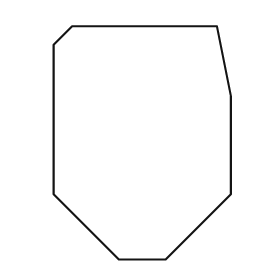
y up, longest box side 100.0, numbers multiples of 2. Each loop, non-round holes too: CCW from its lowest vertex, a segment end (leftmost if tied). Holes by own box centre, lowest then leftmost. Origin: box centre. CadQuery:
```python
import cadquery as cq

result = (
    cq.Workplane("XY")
    .moveTo(-10.0, -50.0)
    .lineTo(10.0, -50.0)
    .lineTo(38.0, -22.0)
    .lineTo(38.0, 20.0)
    .lineTo(32.0, 50.0)
    .lineTo(-30.0, 50.0)
    .lineTo(-38.0, 42.0)
    .lineTo(-38.0, -22.0)
    .close()
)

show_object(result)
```